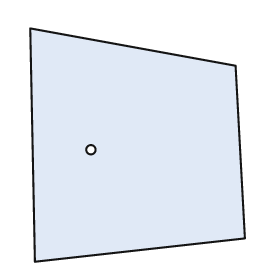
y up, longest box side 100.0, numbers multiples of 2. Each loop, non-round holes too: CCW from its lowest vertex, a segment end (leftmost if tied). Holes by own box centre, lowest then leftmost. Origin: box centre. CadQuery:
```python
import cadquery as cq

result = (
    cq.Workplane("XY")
    .moveTo(-44.0, -50.0)
    .lineTo(46.0, -40.0)
    .lineTo(42.0, 34.0)
    .lineTo(-46.0, 50.0)
    .close()
    .moveTo(-20.0, -2.0)
    .circle(2.0)
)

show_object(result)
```